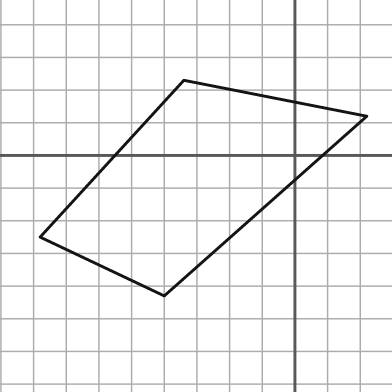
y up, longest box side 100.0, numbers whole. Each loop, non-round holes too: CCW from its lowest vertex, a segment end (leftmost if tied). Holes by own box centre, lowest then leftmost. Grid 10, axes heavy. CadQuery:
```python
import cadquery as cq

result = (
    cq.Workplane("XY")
    .moveTo(-40.0, -43.0)
    .lineTo(22.0, 12.0)
    .lineTo(-34.0, 23.0)
    .lineTo(-78.0, -25.0)
    .close()
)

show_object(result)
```